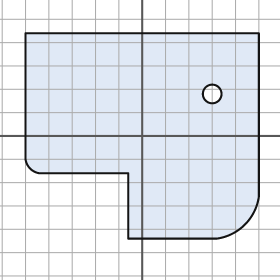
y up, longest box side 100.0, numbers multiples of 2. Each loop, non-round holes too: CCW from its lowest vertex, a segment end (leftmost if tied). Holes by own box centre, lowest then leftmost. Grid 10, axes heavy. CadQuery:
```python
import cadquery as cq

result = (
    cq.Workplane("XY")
    .moveTo(-6.0, -44.0)
    .lineTo(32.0, -44.0)
    .threePointArc((44.0, -38.0), (50.0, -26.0))
    .lineTo(50.0, 44.0)
    .lineTo(-50.0, 44.0)
    .lineTo(-50.0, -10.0)
    .threePointArc((-48.0, -14.0), (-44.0, -16.0))
    .lineTo(-6.0, -16.0)
    .close()
    .moveTo(30.0, 18.0)
    .circle(4.0)
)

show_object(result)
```